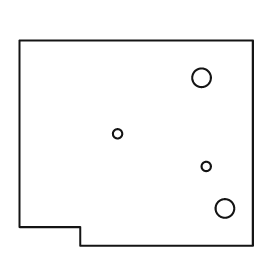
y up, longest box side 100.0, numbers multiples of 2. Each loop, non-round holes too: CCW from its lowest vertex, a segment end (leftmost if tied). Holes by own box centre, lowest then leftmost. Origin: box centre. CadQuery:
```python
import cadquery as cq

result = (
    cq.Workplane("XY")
    .moveTo(-24.0, -44.0)
    .lineTo(50.0, -44.0)
    .lineTo(50.0, 44.0)
    .lineTo(-50.0, 44.0)
    .lineTo(-50.0, -36.0)
    .lineTo(-24.0, -36.0)
    .close()
    .moveTo(38.0, -28.0)
    .circle(4.0)
    .moveTo(30.0, -10.0)
    .circle(2.0)
    .moveTo(-8.0, 4.0)
    .circle(2.0)
    .moveTo(28.0, 28.0)
    .circle(4.0)
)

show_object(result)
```